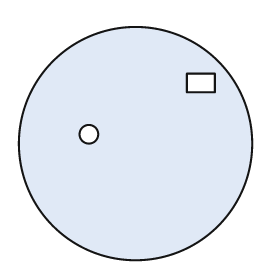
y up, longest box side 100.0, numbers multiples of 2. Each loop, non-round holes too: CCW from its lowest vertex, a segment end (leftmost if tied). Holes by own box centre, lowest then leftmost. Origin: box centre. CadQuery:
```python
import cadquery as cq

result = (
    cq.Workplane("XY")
    .moveTo(0.0, 0.0)
    .circle(50.0)
    .moveTo(-20.0, 4.0)
    .circle(4.0)
    .moveTo(22.0, 22.0)
    .lineTo(34.0, 22.0)
    .lineTo(34.0, 30.0)
    .lineTo(22.0, 30.0)
    .close()
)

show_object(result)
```